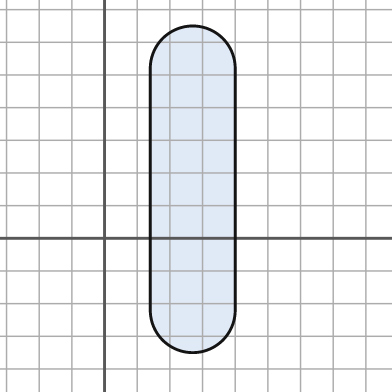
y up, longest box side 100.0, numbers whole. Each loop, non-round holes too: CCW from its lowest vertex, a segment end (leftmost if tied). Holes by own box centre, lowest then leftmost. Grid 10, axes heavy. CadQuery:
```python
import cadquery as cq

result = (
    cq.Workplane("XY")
    .moveTo(14.0, -22.0)
    .threePointArc((27.0, -35.0), (40.0, -22.0))
    .lineTo(40.0, 52.0)
    .threePointArc((27.0, 65.0), (14.0, 52.0))
    .close()
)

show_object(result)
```